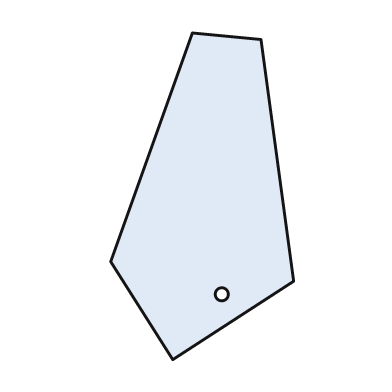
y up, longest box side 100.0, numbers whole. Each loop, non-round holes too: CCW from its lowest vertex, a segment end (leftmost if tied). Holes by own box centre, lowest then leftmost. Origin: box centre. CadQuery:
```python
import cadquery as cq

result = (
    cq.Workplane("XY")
    .moveTo(-9.0, -50.0)
    .lineTo(28.0, -26.0)
    .lineTo(18.0, 48.0)
    .lineTo(-3.0, 50.0)
    .lineTo(-28.0, -20.0)
    .close()
    .moveTo(6.0, -30.0)
    .circle(2.0)
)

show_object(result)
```